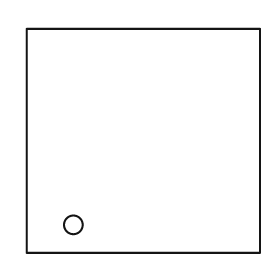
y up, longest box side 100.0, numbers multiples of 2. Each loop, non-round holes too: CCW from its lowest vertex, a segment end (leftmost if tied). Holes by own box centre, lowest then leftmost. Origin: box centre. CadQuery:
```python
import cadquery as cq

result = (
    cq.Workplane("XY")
    .moveTo(-50.0, -48.0)
    .lineTo(50.0, -48.0)
    .lineTo(50.0, 48.0)
    .lineTo(-50.0, 48.0)
    .close()
    .moveTo(-30.0, -36.0)
    .circle(4.0)
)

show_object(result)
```